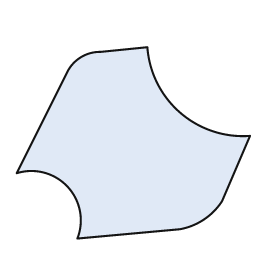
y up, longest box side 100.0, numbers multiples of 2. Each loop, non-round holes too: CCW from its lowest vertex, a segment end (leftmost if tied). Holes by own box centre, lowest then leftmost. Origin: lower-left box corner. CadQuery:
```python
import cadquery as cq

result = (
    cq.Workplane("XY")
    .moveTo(26.0, 0.0)
    .lineTo(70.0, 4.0)
    .threePointArc((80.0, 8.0), (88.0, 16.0))
    .lineTo(100.0, 44.0)
    .threePointArc((70.0, 54.0), (56.0, 82.0))
    .lineTo(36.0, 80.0)
    .threePointArc((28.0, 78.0), (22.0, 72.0))
    .lineTo(0.0, 28.0)
    .threePointArc((22.0, 22.0), (26.0, 0.0))
    .close()
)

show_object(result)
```